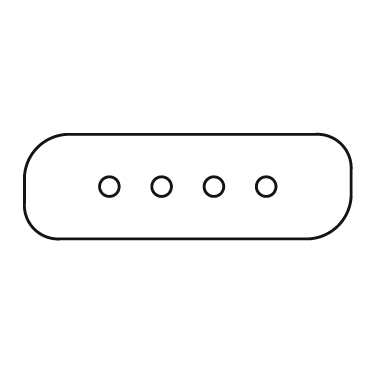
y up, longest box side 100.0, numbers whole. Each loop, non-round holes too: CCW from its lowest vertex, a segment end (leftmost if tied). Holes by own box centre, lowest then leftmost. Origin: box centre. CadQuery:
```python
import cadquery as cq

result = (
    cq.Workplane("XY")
    .moveTo(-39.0, -16.0)
    .lineTo(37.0, -16.0)
    .threePointArc((46.0, -12.0), (50.0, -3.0))
    .lineTo(50.0, 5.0)
    .threePointArc((47.0, 13.0), (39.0, 16.0))
    .lineTo(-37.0, 16.0)
    .threePointArc((-46.0, 12.0), (-50.0, 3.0))
    .lineTo(-50.0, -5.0)
    .threePointArc((-47.0, -13.0), (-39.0, -16.0))
    .close()
    .moveTo(-24.0, 0.0)
    .circle(3.0)
    .moveTo(-8.0, 0.0)
    .circle(3.0)
    .moveTo(8.0, 0.0)
    .circle(3.0)
    .moveTo(24.0, 0.0)
    .circle(3.0)
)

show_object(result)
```